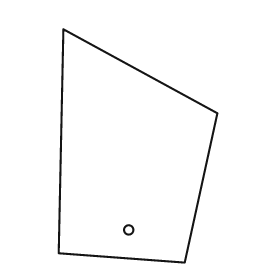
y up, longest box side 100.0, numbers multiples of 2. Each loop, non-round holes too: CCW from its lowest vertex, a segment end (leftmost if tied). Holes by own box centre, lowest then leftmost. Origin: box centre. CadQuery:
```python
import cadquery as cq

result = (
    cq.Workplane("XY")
    .moveTo(20.0, -50.0)
    .lineTo(34.0, 14.0)
    .lineTo(-32.0, 50.0)
    .lineTo(-34.0, -46.0)
    .close()
    .moveTo(-4.0, -36.0)
    .circle(2.0)
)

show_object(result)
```